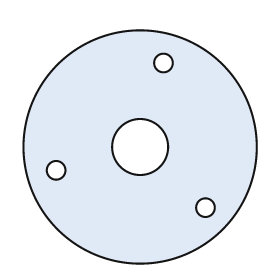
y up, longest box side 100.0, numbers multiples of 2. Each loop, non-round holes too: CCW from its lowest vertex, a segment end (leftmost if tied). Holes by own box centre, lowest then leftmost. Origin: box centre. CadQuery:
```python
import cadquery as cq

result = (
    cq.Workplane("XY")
    .moveTo(0.0, 0.0)
    .circle(50.0)
    .moveTo(28.0, -26.0)
    .circle(4.0)
    .moveTo(-36.0, -10.0)
    .circle(4.0)
    .moveTo(0.0, 0.0)
    .circle(12.0)
    .moveTo(10.0, 36.0)
    .circle(4.0)
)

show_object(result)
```